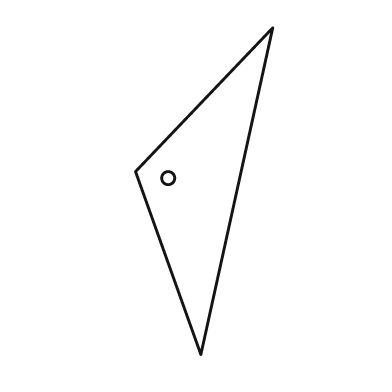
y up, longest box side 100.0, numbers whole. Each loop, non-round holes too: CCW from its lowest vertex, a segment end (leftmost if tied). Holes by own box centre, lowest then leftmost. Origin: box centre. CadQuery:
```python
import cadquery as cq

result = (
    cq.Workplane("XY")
    .moveTo(-1.0, -50.0)
    .lineTo(21.0, 50.0)
    .lineTo(-21.0, 6.0)
    .close()
    .moveTo(-11.0, 4.0)
    .circle(2.0)
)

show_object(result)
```